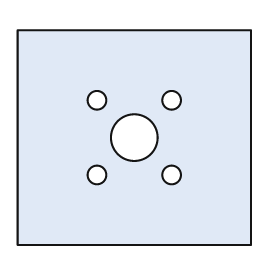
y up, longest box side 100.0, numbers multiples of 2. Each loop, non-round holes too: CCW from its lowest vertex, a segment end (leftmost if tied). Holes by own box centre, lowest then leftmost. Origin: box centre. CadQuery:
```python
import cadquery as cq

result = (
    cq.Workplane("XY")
    .moveTo(-50.0, -46.0)
    .lineTo(50.0, -46.0)
    .lineTo(50.0, 46.0)
    .lineTo(-50.0, 46.0)
    .close()
    .moveTo(-16.0, -16.0)
    .circle(4.0)
    .moveTo(16.0, -16.0)
    .circle(4.0)
    .moveTo(0.0, 0.0)
    .circle(10.0)
    .moveTo(-16.0, 16.0)
    .circle(4.0)
    .moveTo(16.0, 16.0)
    .circle(4.0)
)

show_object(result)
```